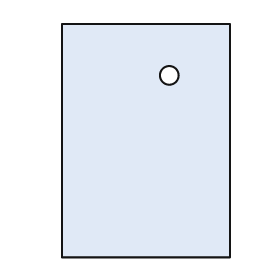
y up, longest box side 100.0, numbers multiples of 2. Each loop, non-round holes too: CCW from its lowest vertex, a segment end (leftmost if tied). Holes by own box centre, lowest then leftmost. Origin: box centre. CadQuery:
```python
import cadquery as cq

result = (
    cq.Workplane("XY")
    .moveTo(-36.0, -50.0)
    .lineTo(36.0, -50.0)
    .lineTo(36.0, 50.0)
    .lineTo(-36.0, 50.0)
    .close()
    .moveTo(10.0, 28.0)
    .circle(4.0)
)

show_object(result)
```